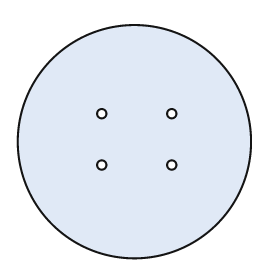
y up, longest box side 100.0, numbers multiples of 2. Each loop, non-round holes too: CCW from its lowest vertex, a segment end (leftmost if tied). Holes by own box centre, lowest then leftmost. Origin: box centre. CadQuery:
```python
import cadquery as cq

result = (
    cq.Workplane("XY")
    .moveTo(0.0, 0.0)
    .circle(50.0)
    .moveTo(-14.0, -10.0)
    .circle(2.0)
    .moveTo(16.0, -10.0)
    .circle(2.0)
    .moveTo(-14.0, 12.0)
    .circle(2.0)
    .moveTo(16.0, 12.0)
    .circle(2.0)
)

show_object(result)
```